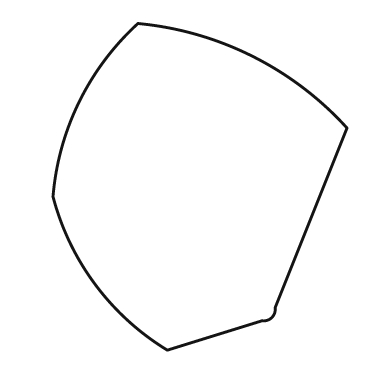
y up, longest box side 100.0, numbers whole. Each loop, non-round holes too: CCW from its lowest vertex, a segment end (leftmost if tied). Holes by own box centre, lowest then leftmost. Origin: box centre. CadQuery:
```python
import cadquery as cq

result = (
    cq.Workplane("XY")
    .moveTo(-10.0, -50.0)
    .lineTo(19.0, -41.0)
    .threePointArc((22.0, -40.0), (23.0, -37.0))
    .lineTo(45.0, 18.0)
    .threePointArc((16.0, 40.0), (-19.0, 50.0))
    .threePointArc((-37.0, 26.0), (-45.0, -3.0))
    .threePointArc((-32.0, -30.0), (-10.0, -50.0))
    .close()
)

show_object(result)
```